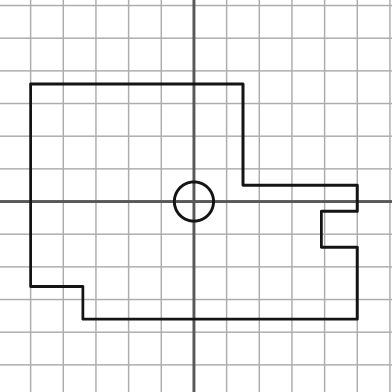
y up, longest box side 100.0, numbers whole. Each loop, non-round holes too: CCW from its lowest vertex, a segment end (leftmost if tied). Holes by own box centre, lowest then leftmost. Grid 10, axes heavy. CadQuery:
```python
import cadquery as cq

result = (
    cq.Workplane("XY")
    .moveTo(-34.0, -36.0)
    .lineTo(50.0, -36.0)
    .lineTo(50.0, -14.0)
    .lineTo(39.0, -14.0)
    .lineTo(39.0, -3.0)
    .lineTo(50.0, -3.0)
    .lineTo(50.0, 5.0)
    .lineTo(15.0, 5.0)
    .lineTo(15.0, 36.0)
    .lineTo(-50.0, 36.0)
    .lineTo(-50.0, -26.0)
    .lineTo(-34.0, -26.0)
    .close()
    .moveTo(0.0, 0.0)
    .circle(6.0)
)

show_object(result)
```